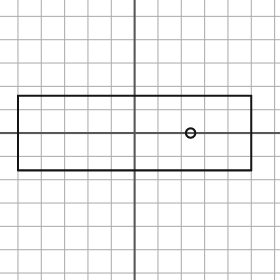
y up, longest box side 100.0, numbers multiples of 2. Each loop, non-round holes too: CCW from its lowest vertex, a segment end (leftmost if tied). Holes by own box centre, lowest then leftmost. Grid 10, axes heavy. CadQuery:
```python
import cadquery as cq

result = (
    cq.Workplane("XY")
    .moveTo(-50.0, -16.0)
    .lineTo(50.0, -16.0)
    .lineTo(50.0, 16.0)
    .lineTo(-50.0, 16.0)
    .close()
    .moveTo(24.0, 0.0)
    .circle(2.0)
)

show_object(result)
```